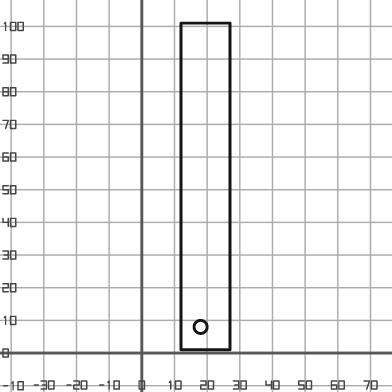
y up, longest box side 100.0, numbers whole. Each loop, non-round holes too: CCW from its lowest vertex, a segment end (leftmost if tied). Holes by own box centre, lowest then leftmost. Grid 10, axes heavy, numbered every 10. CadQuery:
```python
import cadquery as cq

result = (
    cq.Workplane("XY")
    .moveTo(12.0, 1.0)
    .lineTo(27.0, 1.0)
    .lineTo(27.0, 101.0)
    .lineTo(12.0, 101.0)
    .close()
    .moveTo(18.0, 8.0)
    .circle(2.0)
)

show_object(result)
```